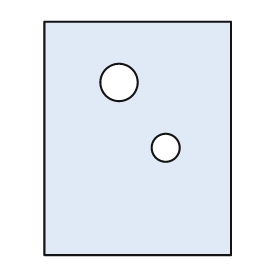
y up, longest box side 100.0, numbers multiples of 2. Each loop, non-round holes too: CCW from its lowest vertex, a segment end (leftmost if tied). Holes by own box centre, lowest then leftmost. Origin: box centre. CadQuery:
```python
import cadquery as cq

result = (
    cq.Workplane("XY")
    .moveTo(-40.0, -50.0)
    .lineTo(40.0, -50.0)
    .lineTo(40.0, 50.0)
    .lineTo(-40.0, 50.0)
    .close()
    .moveTo(12.0, -4.0)
    .circle(6.0)
    .moveTo(-8.0, 24.0)
    .circle(8.0)
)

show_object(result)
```